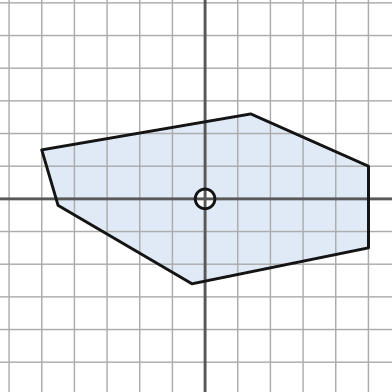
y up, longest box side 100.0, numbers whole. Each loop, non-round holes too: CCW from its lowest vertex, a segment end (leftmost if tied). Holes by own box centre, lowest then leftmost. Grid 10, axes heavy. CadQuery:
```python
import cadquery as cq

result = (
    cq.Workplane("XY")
    .moveTo(-4.0, -26.0)
    .lineTo(50.0, -15.0)
    .lineTo(50.0, 10.0)
    .lineTo(14.0, 26.0)
    .lineTo(-50.0, 15.0)
    .lineTo(-45.0, -2.0)
    .close()
    .moveTo(0.0, 0.0)
    .circle(3.0)
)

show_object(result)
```